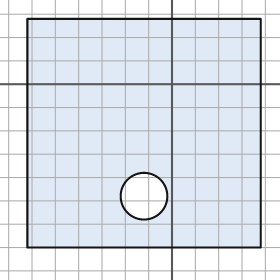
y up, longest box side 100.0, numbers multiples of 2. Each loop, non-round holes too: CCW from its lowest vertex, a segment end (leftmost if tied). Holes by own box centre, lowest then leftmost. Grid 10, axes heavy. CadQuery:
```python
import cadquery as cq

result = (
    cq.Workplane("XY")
    .moveTo(-62.0, -70.0)
    .lineTo(38.0, -70.0)
    .lineTo(38.0, 28.0)
    .lineTo(-62.0, 28.0)
    .close()
    .moveTo(-12.0, -48.0)
    .circle(10.0)
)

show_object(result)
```